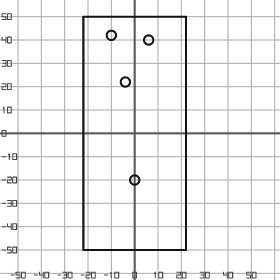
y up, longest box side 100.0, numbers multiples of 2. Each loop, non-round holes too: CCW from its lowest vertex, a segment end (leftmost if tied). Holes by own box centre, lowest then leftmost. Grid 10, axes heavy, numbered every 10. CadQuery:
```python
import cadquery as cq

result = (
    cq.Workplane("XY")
    .moveTo(-22.0, -50.0)
    .lineTo(22.0, -50.0)
    .lineTo(22.0, 50.0)
    .lineTo(-22.0, 50.0)
    .close()
    .moveTo(0.0, -20.0)
    .circle(2.0)
    .moveTo(-4.0, 22.0)
    .circle(2.0)
    .moveTo(6.0, 40.0)
    .circle(2.0)
    .moveTo(-10.0, 42.0)
    .circle(2.0)
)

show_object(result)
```